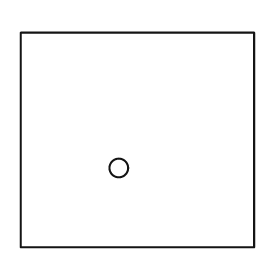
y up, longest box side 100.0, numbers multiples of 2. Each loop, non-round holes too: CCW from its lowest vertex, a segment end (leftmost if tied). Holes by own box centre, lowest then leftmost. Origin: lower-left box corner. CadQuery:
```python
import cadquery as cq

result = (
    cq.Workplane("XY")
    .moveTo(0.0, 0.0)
    .lineTo(100.0, 0.0)
    .lineTo(100.0, 92.0)
    .lineTo(0.0, 92.0)
    .close()
    .moveTo(42.0, 34.0)
    .circle(4.0)
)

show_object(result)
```